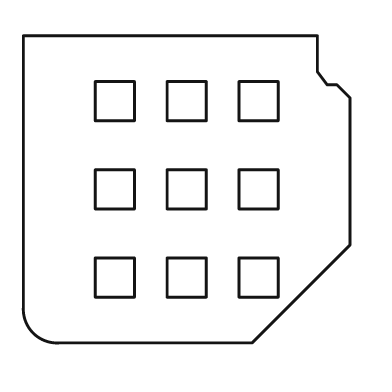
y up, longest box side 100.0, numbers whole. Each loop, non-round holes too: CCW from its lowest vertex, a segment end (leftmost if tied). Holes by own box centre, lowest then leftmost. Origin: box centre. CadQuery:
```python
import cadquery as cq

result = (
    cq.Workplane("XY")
    .moveTo(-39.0, -47.0)
    .lineTo(20.0, -47.0)
    .lineTo(50.0, -17.0)
    .lineTo(50.0, 28.0)
    .lineTo(46.0, 32.0)
    .lineTo(43.0, 32.0)
    .lineTo(40.0, 36.0)
    .lineTo(40.0, 47.0)
    .lineTo(-50.0, 47.0)
    .lineTo(-50.0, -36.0)
    .threePointArc((-47.0, -44.0), (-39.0, -47.0))
    .close()
    .moveTo(-28.0, -33.0)
    .lineTo(-16.0, -33.0)
    .lineTo(-16.0, -21.0)
    .lineTo(-28.0, -21.0)
    .close()
    .moveTo(-6.0, -33.0)
    .lineTo(6.0, -33.0)
    .lineTo(6.0, -21.0)
    .lineTo(-6.0, -21.0)
    .close()
    .moveTo(16.0, -33.0)
    .lineTo(28.0, -33.0)
    .lineTo(28.0, -21.0)
    .lineTo(16.0, -21.0)
    .close()
    .moveTo(-28.0, -6.0)
    .lineTo(-16.0, -6.0)
    .lineTo(-16.0, 6.0)
    .lineTo(-28.0, 6.0)
    .close()
    .moveTo(-6.0, -6.0)
    .lineTo(6.0, -6.0)
    .lineTo(6.0, 6.0)
    .lineTo(-6.0, 6.0)
    .close()
    .moveTo(16.0, -6.0)
    .lineTo(28.0, -6.0)
    .lineTo(28.0, 6.0)
    .lineTo(16.0, 6.0)
    .close()
    .moveTo(-28.0, 21.0)
    .lineTo(-16.0, 21.0)
    .lineTo(-16.0, 33.0)
    .lineTo(-28.0, 33.0)
    .close()
    .moveTo(-6.0, 21.0)
    .lineTo(6.0, 21.0)
    .lineTo(6.0, 33.0)
    .lineTo(-6.0, 33.0)
    .close()
    .moveTo(16.0, 21.0)
    .lineTo(28.0, 21.0)
    .lineTo(28.0, 33.0)
    .lineTo(16.0, 33.0)
    .close()
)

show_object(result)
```